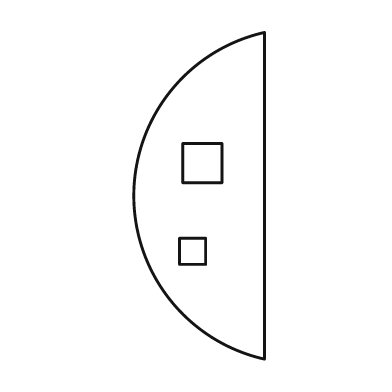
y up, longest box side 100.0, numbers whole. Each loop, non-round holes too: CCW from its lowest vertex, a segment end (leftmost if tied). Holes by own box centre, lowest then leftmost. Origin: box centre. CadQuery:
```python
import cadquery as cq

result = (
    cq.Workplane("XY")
    .moveTo(20.0, -50.0)
    .lineTo(20.0, 50.0)
    .threePointArc((-20.0, 0.0), (20.0, -50.0))
    .close()
    .moveTo(-6.0, -21.0)
    .lineTo(2.0, -21.0)
    .lineTo(2.0, -13.0)
    .lineTo(-6.0, -13.0)
    .close()
    .moveTo(-5.0, 4.0)
    .lineTo(7.0, 4.0)
    .lineTo(7.0, 16.0)
    .lineTo(-5.0, 16.0)
    .close()
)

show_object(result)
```